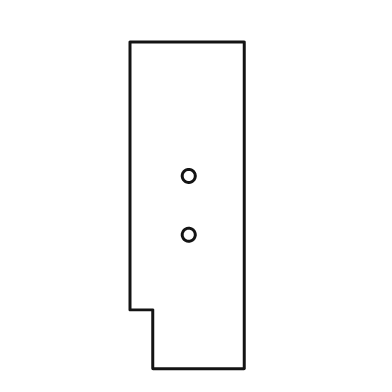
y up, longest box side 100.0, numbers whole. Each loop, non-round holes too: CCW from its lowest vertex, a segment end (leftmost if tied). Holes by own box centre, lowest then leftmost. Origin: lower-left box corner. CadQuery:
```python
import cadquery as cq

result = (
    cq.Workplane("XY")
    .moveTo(7.0, 0.0)
    .lineTo(35.0, 0.0)
    .lineTo(35.0, 100.0)
    .lineTo(0.0, 100.0)
    .lineTo(0.0, 18.0)
    .lineTo(7.0, 18.0)
    .close()
    .moveTo(18.0, 41.0)
    .circle(2.0)
    .moveTo(18.0, 59.0)
    .circle(2.0)
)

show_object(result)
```